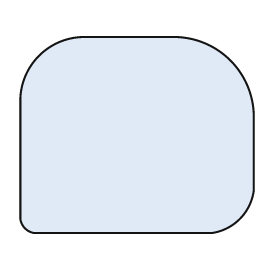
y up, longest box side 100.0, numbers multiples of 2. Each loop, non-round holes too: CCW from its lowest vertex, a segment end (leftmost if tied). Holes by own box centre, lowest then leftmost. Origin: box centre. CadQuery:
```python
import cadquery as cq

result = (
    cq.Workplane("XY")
    .moveTo(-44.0, -42.0)
    .lineTo(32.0, -42.0)
    .threePointArc((44.0, -36.0), (50.0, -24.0))
    .lineTo(50.0, 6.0)
    .threePointArc((40.0, 32.0), (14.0, 42.0))
    .lineTo(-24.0, 42.0)
    .threePointArc((-42.0, 34.0), (-50.0, 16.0))
    .lineTo(-50.0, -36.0)
    .threePointArc((-48.0, -40.0), (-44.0, -42.0))
    .close()
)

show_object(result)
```